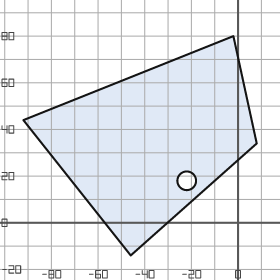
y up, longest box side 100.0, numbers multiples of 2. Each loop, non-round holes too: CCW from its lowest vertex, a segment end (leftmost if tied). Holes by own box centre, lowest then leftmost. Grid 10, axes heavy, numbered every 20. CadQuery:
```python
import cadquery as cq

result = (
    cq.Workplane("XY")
    .moveTo(-46.0, -14.0)
    .lineTo(8.0, 34.0)
    .lineTo(-2.0, 80.0)
    .lineTo(-92.0, 44.0)
    .close()
    .moveTo(-22.0, 18.0)
    .circle(4.0)
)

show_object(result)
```